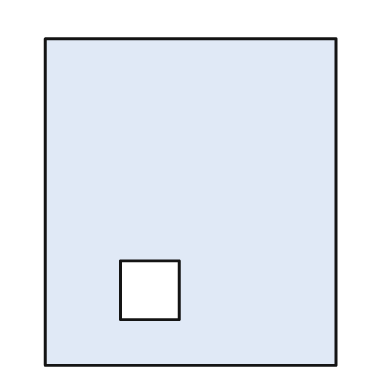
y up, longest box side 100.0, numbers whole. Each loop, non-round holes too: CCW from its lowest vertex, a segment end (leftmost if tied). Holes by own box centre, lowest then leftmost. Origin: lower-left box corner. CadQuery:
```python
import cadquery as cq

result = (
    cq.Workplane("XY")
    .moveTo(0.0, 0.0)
    .lineTo(89.0, 0.0)
    .lineTo(89.0, 100.0)
    .lineTo(0.0, 100.0)
    .close()
    .moveTo(23.0, 14.0)
    .lineTo(41.0, 14.0)
    .lineTo(41.0, 32.0)
    .lineTo(23.0, 32.0)
    .close()
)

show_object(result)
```